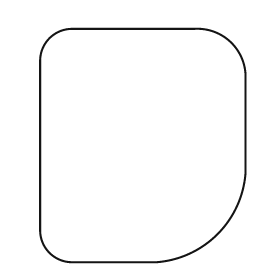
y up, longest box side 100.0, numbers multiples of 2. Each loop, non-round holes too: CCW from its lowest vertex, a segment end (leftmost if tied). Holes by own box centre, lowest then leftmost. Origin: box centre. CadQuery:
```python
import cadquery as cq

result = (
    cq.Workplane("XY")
    .moveTo(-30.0, -50.0)
    .lineTo(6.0, -50.0)
    .threePointArc((32.0, -38.0), (44.0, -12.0))
    .lineTo(44.0, 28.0)
    .threePointArc((38.0, 44.0), (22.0, 50.0))
    .lineTo(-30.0, 50.0)
    .threePointArc((-40.0, 46.0), (-44.0, 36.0))
    .lineTo(-44.0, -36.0)
    .threePointArc((-40.0, -46.0), (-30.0, -50.0))
    .close()
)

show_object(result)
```